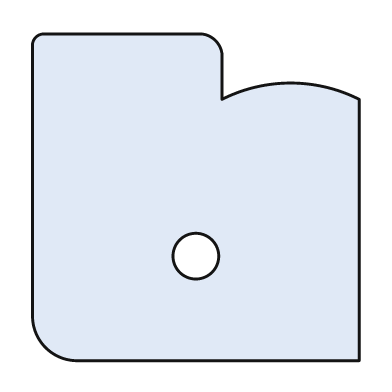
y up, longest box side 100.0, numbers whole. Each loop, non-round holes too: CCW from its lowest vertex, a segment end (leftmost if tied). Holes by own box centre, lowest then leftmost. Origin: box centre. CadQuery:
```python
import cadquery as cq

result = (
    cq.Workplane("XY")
    .moveTo(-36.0, -50.0)
    .lineTo(50.0, -50.0)
    .lineTo(50.0, 30.0)
    .threePointArc((29.0, 35.0), (8.0, 30.0))
    .lineTo(8.0, 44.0)
    .threePointArc((6.0, 48.0), (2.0, 50.0))
    .lineTo(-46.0, 50.0)
    .threePointArc((-49.0, 49.0), (-50.0, 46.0))
    .lineTo(-50.0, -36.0)
    .threePointArc((-46.0, -46.0), (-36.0, -50.0))
    .close()
    .moveTo(0.0, -18.0)
    .circle(7.0)
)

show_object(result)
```